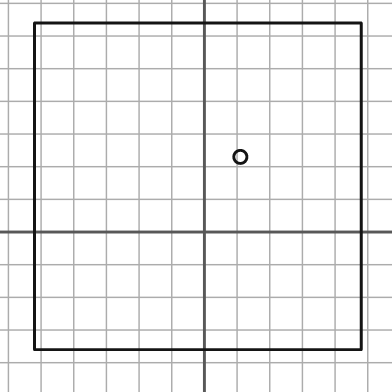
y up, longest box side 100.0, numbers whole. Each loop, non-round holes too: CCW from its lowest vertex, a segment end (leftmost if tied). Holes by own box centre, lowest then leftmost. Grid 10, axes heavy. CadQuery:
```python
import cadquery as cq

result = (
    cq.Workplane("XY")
    .moveTo(-52.0, -36.0)
    .lineTo(48.0, -36.0)
    .lineTo(48.0, 64.0)
    .lineTo(-52.0, 64.0)
    .close()
    .moveTo(11.0, 23.0)
    .circle(2.0)
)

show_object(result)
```